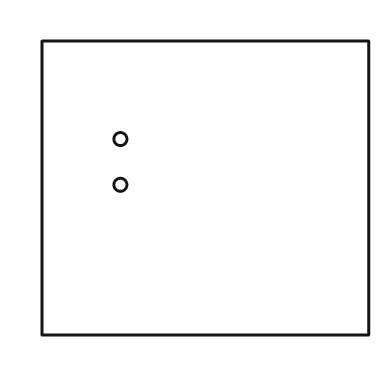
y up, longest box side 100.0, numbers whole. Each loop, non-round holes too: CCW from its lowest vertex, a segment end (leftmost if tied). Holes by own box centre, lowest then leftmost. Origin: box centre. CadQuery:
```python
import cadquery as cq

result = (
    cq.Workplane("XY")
    .moveTo(-50.0, -45.0)
    .lineTo(50.0, -45.0)
    .lineTo(50.0, 45.0)
    .lineTo(-50.0, 45.0)
    .close()
    .moveTo(-26.0, 1.0)
    .circle(2.0)
    .moveTo(-26.0, 15.0)
    .circle(2.0)
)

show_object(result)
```